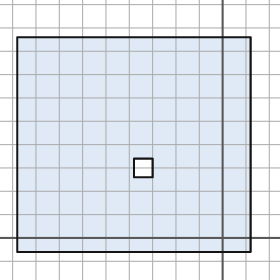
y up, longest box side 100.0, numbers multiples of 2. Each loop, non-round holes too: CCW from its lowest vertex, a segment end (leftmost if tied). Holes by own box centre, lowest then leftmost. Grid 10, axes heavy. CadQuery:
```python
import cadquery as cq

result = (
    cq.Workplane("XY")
    .moveTo(-88.0, -6.0)
    .lineTo(12.0, -6.0)
    .lineTo(12.0, 86.0)
    .lineTo(-88.0, 86.0)
    .close()
    .moveTo(-38.0, 26.0)
    .lineTo(-30.0, 26.0)
    .lineTo(-30.0, 34.0)
    .lineTo(-38.0, 34.0)
    .close()
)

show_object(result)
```